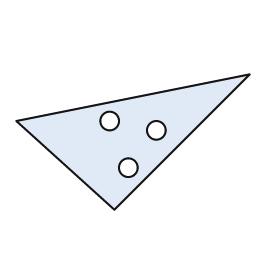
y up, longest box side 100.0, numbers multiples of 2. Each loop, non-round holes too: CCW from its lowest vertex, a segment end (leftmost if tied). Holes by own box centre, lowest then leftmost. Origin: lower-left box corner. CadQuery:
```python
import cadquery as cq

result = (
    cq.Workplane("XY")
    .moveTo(42.0, 0.0)
    .lineTo(100.0, 58.0)
    .lineTo(0.0, 38.0)
    .close()
    .moveTo(48.0, 18.0)
    .circle(4.0)
    .moveTo(60.0, 34.0)
    .circle(4.0)
    .moveTo(40.0, 38.0)
    .circle(4.0)
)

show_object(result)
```